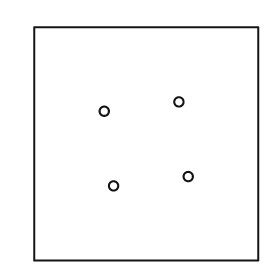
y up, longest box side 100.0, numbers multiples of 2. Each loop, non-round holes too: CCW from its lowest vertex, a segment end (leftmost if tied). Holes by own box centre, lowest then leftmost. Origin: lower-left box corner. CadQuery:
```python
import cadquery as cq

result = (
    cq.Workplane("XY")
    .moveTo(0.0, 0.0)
    .lineTo(96.0, 0.0)
    .lineTo(96.0, 100.0)
    .lineTo(0.0, 100.0)
    .close()
    .moveTo(34.0, 32.0)
    .circle(2.0)
    .moveTo(66.0, 36.0)
    .circle(2.0)
    .moveTo(30.0, 64.0)
    .circle(2.0)
    .moveTo(62.0, 68.0)
    .circle(2.0)
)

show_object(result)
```